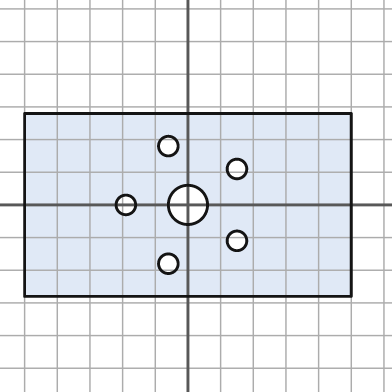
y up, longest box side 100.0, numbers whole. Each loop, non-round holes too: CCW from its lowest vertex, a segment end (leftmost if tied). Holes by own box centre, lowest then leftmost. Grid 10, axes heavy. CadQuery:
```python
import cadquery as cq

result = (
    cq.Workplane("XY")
    .moveTo(-50.0, -28.0)
    .lineTo(50.0, -28.0)
    .lineTo(50.0, 28.0)
    .lineTo(-50.0, 28.0)
    .close()
    .moveTo(-6.0, -18.0)
    .circle(3.0)
    .moveTo(15.0, -11.0)
    .circle(3.0)
    .moveTo(-19.0, 0.0)
    .circle(3.0)
    .moveTo(0.0, 0.0)
    .circle(6.0)
    .moveTo(15.0, 11.0)
    .circle(3.0)
    .moveTo(-6.0, 18.0)
    .circle(3.0)
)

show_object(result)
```